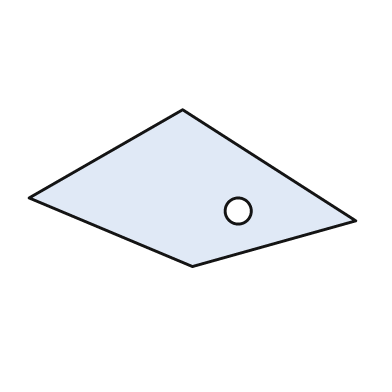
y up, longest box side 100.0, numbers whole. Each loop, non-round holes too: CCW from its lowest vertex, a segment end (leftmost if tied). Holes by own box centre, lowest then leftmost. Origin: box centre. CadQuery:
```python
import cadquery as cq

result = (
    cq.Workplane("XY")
    .moveTo(0.0, -24.0)
    .lineTo(50.0, -10.0)
    .lineTo(-3.0, 24.0)
    .lineTo(-50.0, -3.0)
    .close()
    .moveTo(14.0, -7.0)
    .circle(4.0)
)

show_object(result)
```